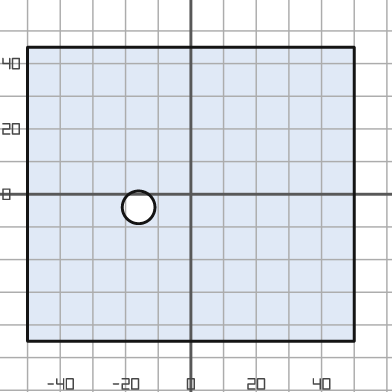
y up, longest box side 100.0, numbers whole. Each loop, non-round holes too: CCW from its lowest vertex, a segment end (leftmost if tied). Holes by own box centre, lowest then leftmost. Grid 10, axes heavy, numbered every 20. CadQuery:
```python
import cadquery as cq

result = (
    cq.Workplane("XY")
    .moveTo(-50.0, -45.0)
    .lineTo(50.0, -45.0)
    .lineTo(50.0, 45.0)
    .lineTo(-50.0, 45.0)
    .close()
    .moveTo(-16.0, -4.0)
    .circle(5.0)
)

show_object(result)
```